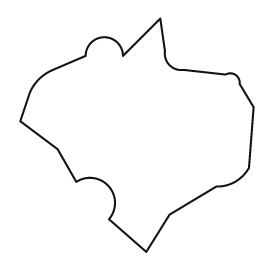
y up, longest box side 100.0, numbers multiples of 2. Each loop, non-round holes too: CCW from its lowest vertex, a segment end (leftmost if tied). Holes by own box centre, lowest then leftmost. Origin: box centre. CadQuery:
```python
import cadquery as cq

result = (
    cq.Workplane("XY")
    .moveTo(4.0, -50.0)
    .lineTo(14.0, -34.0)
    .lineTo(34.0, -22.0)
    .threePointArc((42.0, -20.0), (48.0, -14.0))
    .lineTo(50.0, 12.0)
    .lineTo(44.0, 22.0)
    .threePointArc((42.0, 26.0), (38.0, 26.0))
    .lineTo(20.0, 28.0)
    .threePointArc((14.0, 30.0), (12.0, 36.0))
    .lineTo(10.0, 50.0)
    .lineTo(-6.0, 34.0)
    .threePointArc((-14.0, 42.0), (-22.0, 34.0))
    .lineTo(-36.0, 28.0)
    .threePointArc((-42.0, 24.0), (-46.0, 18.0))
    .lineTo(-50.0, 6.0)
    .lineTo(-34.0, -6.0)
    .lineTo(-26.0, -20.0)
    .threePointArc((-12.0, -22.0), (-12.0, -36.0))
    .close()
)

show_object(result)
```